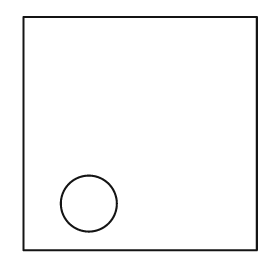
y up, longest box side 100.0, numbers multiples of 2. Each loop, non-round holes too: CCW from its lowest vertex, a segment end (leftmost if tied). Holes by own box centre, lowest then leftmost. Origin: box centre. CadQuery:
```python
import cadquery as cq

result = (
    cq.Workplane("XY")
    .moveTo(-50.0, -50.0)
    .lineTo(50.0, -50.0)
    .lineTo(50.0, 50.0)
    .lineTo(-50.0, 50.0)
    .close()
    .moveTo(-22.0, -30.0)
    .circle(12.0)
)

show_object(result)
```